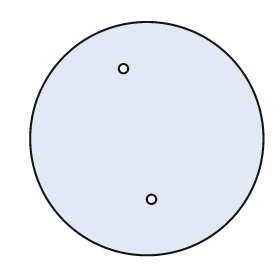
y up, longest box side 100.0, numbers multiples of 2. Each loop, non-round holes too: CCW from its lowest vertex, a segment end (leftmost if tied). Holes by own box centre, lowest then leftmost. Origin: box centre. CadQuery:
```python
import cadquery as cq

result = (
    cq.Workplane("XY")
    .moveTo(0.0, 0.0)
    .circle(50.0)
    .moveTo(2.0, -26.0)
    .circle(2.0)
    .moveTo(-10.0, 30.0)
    .circle(2.0)
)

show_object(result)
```